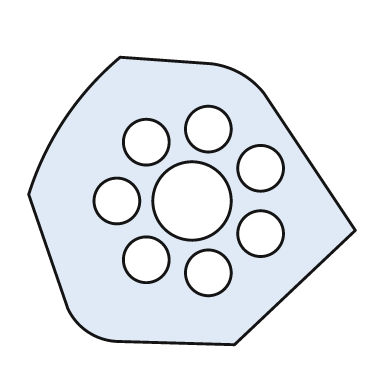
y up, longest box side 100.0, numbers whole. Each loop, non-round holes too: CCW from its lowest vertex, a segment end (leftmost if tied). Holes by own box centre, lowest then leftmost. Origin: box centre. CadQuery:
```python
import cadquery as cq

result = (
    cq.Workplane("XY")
    .moveTo(13.0, -44.0)
    .lineTo(50.0, -9.0)
    .lineTo(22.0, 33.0)
    .threePointArc((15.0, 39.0), (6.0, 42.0))
    .lineTo(-22.0, 44.0)
    .threePointArc((-39.0, 25.0), (-50.0, 2.0))
    .lineTo(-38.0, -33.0)
    .threePointArc((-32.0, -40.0), (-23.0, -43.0))
    .close()
    .moveTo(5.0, -22.0)
    .circle(7.0)
    .moveTo(-14.0, -18.0)
    .circle(7.0)
    .moveTo(21.0, -10.0)
    .circle(7.0)
    .moveTo(-23.0, 0.0)
    .circle(7.0)
    .moveTo(0.0, 0.0)
    .circle(12.0)
    .moveTo(21.0, 10.0)
    .circle(7.0)
    .moveTo(-14.0, 18.0)
    .circle(7.0)
    .moveTo(5.0, 22.0)
    .circle(7.0)
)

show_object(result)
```